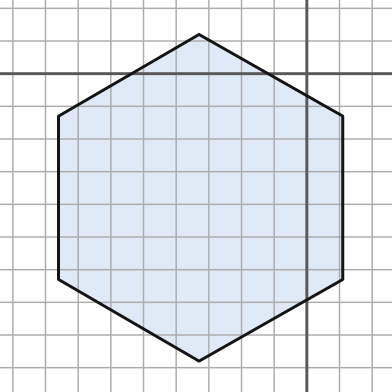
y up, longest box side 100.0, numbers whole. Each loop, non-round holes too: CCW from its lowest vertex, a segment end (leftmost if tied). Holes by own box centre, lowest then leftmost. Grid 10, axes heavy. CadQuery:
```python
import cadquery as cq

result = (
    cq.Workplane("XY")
    .moveTo(-33.0, -88.0)
    .lineTo(11.0, -63.0)
    .lineTo(11.0, -13.0)
    .lineTo(-33.0, 12.0)
    .lineTo(-76.0, -13.0)
    .lineTo(-76.0, -63.0)
    .close()
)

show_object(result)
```